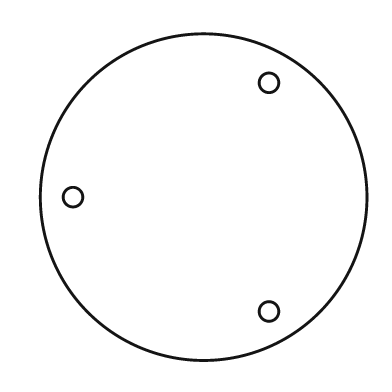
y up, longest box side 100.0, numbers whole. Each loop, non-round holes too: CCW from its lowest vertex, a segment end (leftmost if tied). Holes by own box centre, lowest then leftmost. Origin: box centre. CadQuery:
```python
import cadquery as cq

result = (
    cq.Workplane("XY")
    .moveTo(0.0, 0.0)
    .circle(50.0)
    .moveTo(20.0, -35.0)
    .circle(3.0)
    .moveTo(-40.0, 0.0)
    .circle(3.0)
    .moveTo(20.0, 35.0)
    .circle(3.0)
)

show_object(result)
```